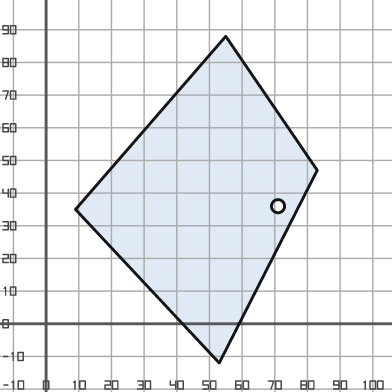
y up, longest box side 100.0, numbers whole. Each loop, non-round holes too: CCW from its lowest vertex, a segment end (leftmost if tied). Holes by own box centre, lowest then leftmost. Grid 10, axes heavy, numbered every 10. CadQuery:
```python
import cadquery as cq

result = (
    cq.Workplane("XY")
    .moveTo(53.0, -12.0)
    .lineTo(83.0, 47.0)
    .lineTo(55.0, 88.0)
    .lineTo(9.0, 35.0)
    .close()
    .moveTo(71.0, 36.0)
    .circle(2.0)
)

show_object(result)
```